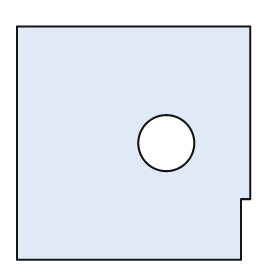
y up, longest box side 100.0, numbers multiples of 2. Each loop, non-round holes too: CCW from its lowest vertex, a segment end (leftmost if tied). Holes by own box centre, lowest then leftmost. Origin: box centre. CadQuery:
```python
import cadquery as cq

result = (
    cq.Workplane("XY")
    .moveTo(-50.0, -50.0)
    .lineTo(46.0, -50.0)
    .lineTo(46.0, -24.0)
    .lineTo(50.0, -24.0)
    .lineTo(50.0, 50.0)
    .lineTo(-50.0, 50.0)
    .close()
    .moveTo(14.0, 0.0)
    .circle(12.0)
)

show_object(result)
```